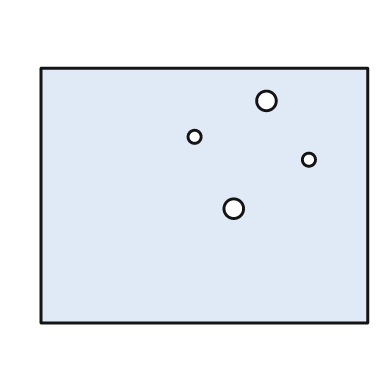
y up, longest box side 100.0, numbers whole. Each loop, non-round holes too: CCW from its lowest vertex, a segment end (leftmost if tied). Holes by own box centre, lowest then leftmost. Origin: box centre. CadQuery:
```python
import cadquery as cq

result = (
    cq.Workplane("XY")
    .moveTo(-50.0, -39.0)
    .lineTo(50.0, -39.0)
    .lineTo(50.0, 39.0)
    .lineTo(-50.0, 39.0)
    .close()
    .moveTo(9.0, -4.0)
    .circle(3.0)
    .moveTo(32.0, 11.0)
    .circle(2.0)
    .moveTo(-3.0, 18.0)
    .circle(2.0)
    .moveTo(19.0, 29.0)
    .circle(3.0)
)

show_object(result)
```